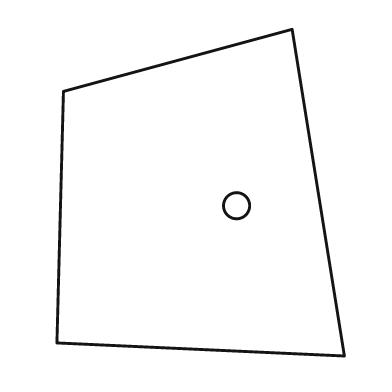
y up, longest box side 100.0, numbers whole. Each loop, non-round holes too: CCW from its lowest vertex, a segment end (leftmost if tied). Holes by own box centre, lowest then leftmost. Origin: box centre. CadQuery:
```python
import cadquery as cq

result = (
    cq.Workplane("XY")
    .moveTo(44.0, -50.0)
    .lineTo(28.0, 50.0)
    .lineTo(-42.0, 31.0)
    .lineTo(-44.0, -46.0)
    .close()
    .moveTo(11.0, -4.0)
    .circle(4.0)
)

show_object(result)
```